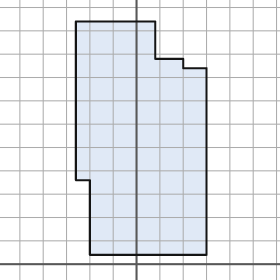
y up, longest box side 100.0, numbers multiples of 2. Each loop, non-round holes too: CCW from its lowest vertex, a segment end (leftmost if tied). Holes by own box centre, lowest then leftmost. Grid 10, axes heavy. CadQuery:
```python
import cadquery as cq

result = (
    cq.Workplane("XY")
    .moveTo(-20.0, 4.0)
    .lineTo(30.0, 4.0)
    .lineTo(30.0, 84.0)
    .lineTo(20.0, 84.0)
    .lineTo(20.0, 88.0)
    .lineTo(8.0, 88.0)
    .lineTo(8.0, 104.0)
    .lineTo(-26.0, 104.0)
    .lineTo(-26.0, 36.0)
    .lineTo(-20.0, 36.0)
    .close()
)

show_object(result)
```